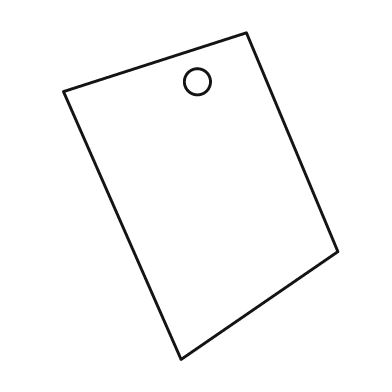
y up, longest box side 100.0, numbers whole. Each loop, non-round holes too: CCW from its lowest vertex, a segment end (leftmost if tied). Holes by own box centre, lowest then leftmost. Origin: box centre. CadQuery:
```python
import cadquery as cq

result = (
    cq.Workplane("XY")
    .moveTo(-6.0, -50.0)
    .lineTo(42.0, -17.0)
    .lineTo(14.0, 50.0)
    .lineTo(-42.0, 32.0)
    .close()
    .moveTo(-1.0, 35.0)
    .circle(4.0)
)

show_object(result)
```